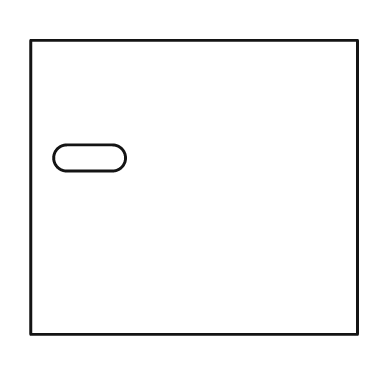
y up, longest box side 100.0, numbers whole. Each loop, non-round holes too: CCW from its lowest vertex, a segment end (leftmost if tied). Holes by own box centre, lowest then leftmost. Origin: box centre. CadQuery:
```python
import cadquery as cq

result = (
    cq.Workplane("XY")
    .moveTo(-50.0, -45.0)
    .lineTo(50.0, -45.0)
    .lineTo(50.0, 45.0)
    .lineTo(-50.0, 45.0)
    .close()
    .moveTo(-39.0, 5.0)
    .lineTo(-25.0, 5.0)
    .threePointArc((-21.0, 9.0), (-25.0, 13.0))
    .lineTo(-39.0, 13.0)
    .threePointArc((-43.0, 9.0), (-39.0, 5.0))
    .close()
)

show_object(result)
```